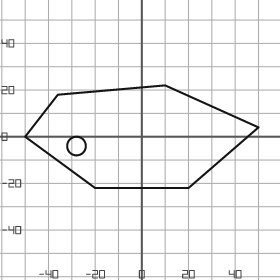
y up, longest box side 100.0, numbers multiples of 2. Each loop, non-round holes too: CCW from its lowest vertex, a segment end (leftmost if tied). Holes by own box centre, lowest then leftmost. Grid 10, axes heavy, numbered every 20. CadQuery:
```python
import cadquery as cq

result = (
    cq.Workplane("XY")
    .moveTo(-20.0, -22.0)
    .lineTo(20.0, -22.0)
    .lineTo(50.0, 4.0)
    .lineTo(10.0, 22.0)
    .lineTo(-36.0, 18.0)
    .lineTo(-50.0, 0.0)
    .close()
    .moveTo(-28.0, -4.0)
    .circle(4.0)
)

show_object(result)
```